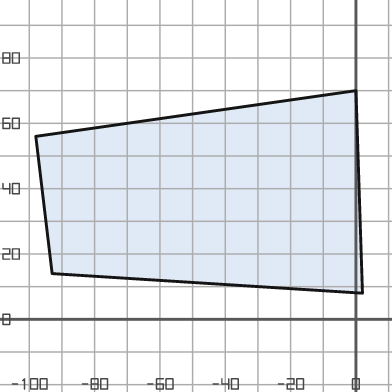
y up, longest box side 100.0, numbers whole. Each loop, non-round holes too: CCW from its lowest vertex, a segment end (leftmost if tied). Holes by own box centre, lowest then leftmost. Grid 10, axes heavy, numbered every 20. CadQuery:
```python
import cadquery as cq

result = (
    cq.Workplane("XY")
    .moveTo(2.0, 8.0)
    .lineTo(0.0, 70.0)
    .lineTo(-98.0, 56.0)
    .lineTo(-93.0, 14.0)
    .close()
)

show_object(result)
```